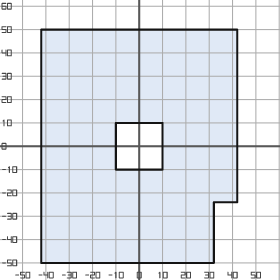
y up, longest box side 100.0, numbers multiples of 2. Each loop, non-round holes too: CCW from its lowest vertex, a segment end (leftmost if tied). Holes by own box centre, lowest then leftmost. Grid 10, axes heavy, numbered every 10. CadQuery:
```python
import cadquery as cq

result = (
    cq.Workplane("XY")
    .moveTo(-42.0, -50.0)
    .lineTo(32.0, -50.0)
    .lineTo(32.0, -24.0)
    .lineTo(42.0, -24.0)
    .lineTo(42.0, 50.0)
    .lineTo(-42.0, 50.0)
    .close()
    .moveTo(-10.0, -10.0)
    .lineTo(10.0, -10.0)
    .lineTo(10.0, 10.0)
    .lineTo(-10.0, 10.0)
    .close()
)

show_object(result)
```